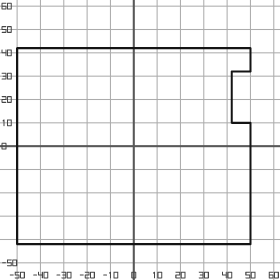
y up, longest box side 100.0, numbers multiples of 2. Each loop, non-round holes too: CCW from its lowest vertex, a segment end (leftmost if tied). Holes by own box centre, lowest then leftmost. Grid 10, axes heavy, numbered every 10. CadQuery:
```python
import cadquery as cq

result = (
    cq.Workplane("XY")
    .moveTo(-50.0, -42.0)
    .lineTo(50.0, -42.0)
    .lineTo(50.0, 10.0)
    .lineTo(42.0, 10.0)
    .lineTo(42.0, 32.0)
    .lineTo(50.0, 32.0)
    .lineTo(50.0, 42.0)
    .lineTo(-50.0, 42.0)
    .close()
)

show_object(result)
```